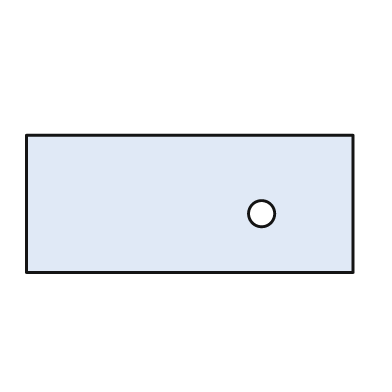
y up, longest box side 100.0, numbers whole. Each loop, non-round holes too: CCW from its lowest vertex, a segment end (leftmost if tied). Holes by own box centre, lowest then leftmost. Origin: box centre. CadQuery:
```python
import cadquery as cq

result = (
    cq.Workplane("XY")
    .moveTo(-50.0, -21.0)
    .lineTo(50.0, -21.0)
    .lineTo(50.0, 21.0)
    .lineTo(-50.0, 21.0)
    .close()
    .moveTo(22.0, -3.0)
    .circle(4.0)
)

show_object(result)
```